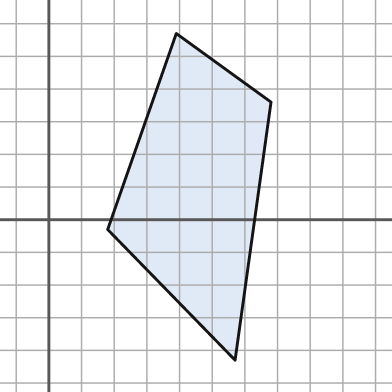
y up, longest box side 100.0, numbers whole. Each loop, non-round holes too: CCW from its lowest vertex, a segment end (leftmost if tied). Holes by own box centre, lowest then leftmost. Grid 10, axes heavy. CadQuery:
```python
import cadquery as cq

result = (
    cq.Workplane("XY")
    .moveTo(57.0, -43.0)
    .lineTo(68.0, 36.0)
    .lineTo(39.0, 57.0)
    .lineTo(18.0, -3.0)
    .close()
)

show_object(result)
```